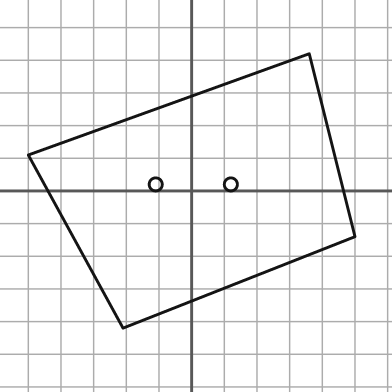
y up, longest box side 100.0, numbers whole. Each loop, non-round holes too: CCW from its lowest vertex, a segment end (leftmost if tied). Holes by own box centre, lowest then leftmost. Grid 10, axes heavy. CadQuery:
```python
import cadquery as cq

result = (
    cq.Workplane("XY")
    .moveTo(-21.0, -42.0)
    .lineTo(50.0, -14.0)
    .lineTo(36.0, 42.0)
    .lineTo(-50.0, 11.0)
    .close()
    .moveTo(-11.0, 2.0)
    .circle(2.0)
    .moveTo(12.0, 2.0)
    .circle(2.0)
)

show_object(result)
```